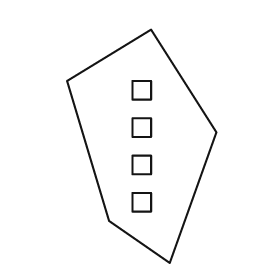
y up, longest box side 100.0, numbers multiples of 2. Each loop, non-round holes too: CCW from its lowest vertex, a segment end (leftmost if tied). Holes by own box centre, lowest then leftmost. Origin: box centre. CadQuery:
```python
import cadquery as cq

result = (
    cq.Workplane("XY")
    .moveTo(12.0, -50.0)
    .lineTo(32.0, 6.0)
    .lineTo(4.0, 50.0)
    .lineTo(-32.0, 28.0)
    .lineTo(-14.0, -32.0)
    .close()
    .moveTo(-4.0, -28.0)
    .lineTo(4.0, -28.0)
    .lineTo(4.0, -20.0)
    .lineTo(-4.0, -20.0)
    .close()
    .moveTo(-4.0, -12.0)
    .lineTo(4.0, -12.0)
    .lineTo(4.0, -4.0)
    .lineTo(-4.0, -4.0)
    .close()
    .moveTo(-4.0, 4.0)
    .lineTo(4.0, 4.0)
    .lineTo(4.0, 12.0)
    .lineTo(-4.0, 12.0)
    .close()
    .moveTo(-4.0, 20.0)
    .lineTo(4.0, 20.0)
    .lineTo(4.0, 28.0)
    .lineTo(-4.0, 28.0)
    .close()
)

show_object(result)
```